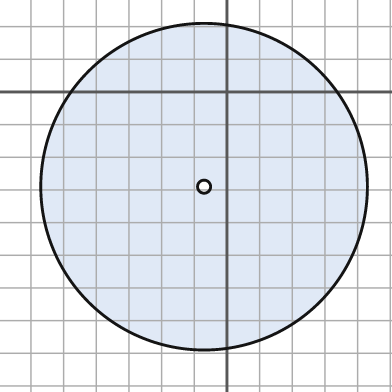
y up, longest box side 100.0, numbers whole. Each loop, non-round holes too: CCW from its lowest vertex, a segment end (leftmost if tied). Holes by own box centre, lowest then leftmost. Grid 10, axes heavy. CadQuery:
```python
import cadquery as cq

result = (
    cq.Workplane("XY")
    .moveTo(-7.0, -29.0)
    .circle(50.0)
    .moveTo(-7.0, -29.0)
    .circle(2.0)
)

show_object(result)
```